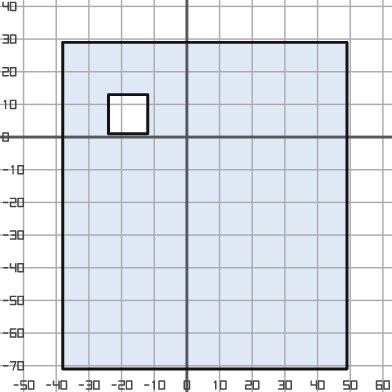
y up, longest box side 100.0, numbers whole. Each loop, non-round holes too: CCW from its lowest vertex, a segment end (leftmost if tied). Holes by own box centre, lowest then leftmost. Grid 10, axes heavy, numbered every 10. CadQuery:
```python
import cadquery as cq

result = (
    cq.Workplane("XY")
    .moveTo(-38.0, -71.0)
    .lineTo(49.0, -71.0)
    .lineTo(49.0, 29.0)
    .lineTo(-38.0, 29.0)
    .close()
    .moveTo(-24.0, 1.0)
    .lineTo(-12.0, 1.0)
    .lineTo(-12.0, 13.0)
    .lineTo(-24.0, 13.0)
    .close()
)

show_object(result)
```